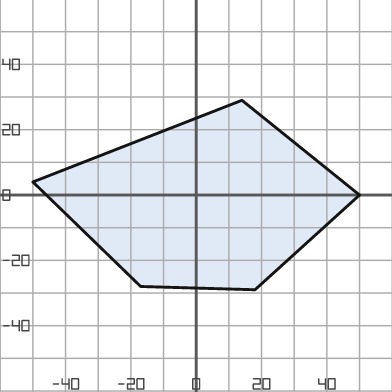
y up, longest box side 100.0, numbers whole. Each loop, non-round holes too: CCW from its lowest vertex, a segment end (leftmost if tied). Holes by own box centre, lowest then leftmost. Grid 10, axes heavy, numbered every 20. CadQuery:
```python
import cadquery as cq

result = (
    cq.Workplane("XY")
    .moveTo(18.0, -29.0)
    .lineTo(50.0, 0.0)
    .lineTo(14.0, 29.0)
    .lineTo(-50.0, 4.0)
    .lineTo(-17.0, -28.0)
    .close()
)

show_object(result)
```